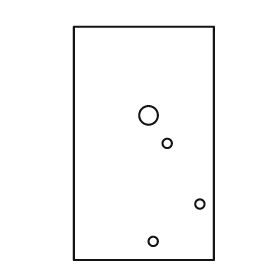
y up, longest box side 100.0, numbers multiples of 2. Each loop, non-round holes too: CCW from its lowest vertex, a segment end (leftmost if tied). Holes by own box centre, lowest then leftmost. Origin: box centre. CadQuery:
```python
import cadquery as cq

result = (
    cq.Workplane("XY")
    .moveTo(-30.0, -50.0)
    .lineTo(30.0, -50.0)
    .lineTo(30.0, 50.0)
    .lineTo(-30.0, 50.0)
    .close()
    .moveTo(4.0, -42.0)
    .circle(2.0)
    .moveTo(24.0, -26.0)
    .circle(2.0)
    .moveTo(10.0, 0.0)
    .circle(2.0)
    .moveTo(2.0, 12.0)
    .circle(4.0)
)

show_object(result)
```